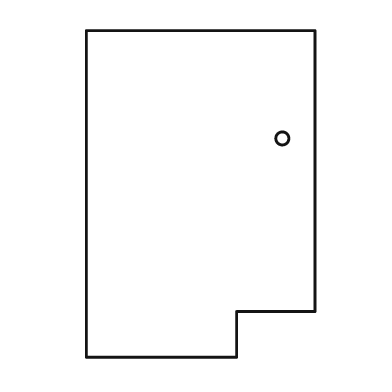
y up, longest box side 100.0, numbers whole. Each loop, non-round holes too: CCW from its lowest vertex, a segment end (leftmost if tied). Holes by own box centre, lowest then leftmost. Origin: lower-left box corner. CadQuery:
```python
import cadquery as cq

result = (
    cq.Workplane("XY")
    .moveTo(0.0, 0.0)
    .lineTo(46.0, 0.0)
    .lineTo(46.0, 14.0)
    .lineTo(70.0, 14.0)
    .lineTo(70.0, 100.0)
    .lineTo(0.0, 100.0)
    .close()
    .moveTo(60.0, 67.0)
    .circle(2.0)
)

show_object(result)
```